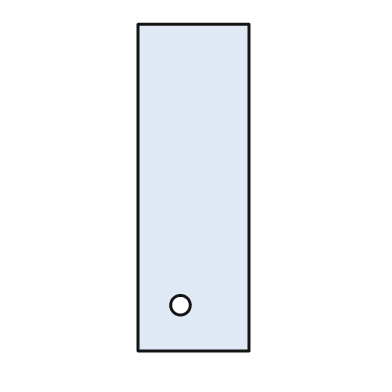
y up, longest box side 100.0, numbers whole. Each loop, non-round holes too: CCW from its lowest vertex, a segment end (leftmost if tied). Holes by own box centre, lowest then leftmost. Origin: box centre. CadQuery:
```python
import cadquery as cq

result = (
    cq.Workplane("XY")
    .moveTo(-17.0, -50.0)
    .lineTo(17.0, -50.0)
    .lineTo(17.0, 50.0)
    .lineTo(-17.0, 50.0)
    .close()
    .moveTo(-4.0, -36.0)
    .circle(3.0)
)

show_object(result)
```